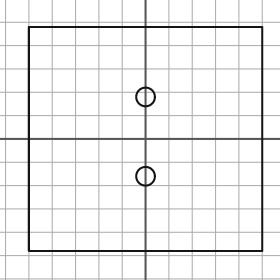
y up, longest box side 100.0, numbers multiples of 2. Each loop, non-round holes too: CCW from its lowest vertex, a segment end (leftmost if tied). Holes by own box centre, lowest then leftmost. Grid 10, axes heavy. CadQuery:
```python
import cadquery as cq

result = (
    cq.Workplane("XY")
    .moveTo(-50.0, -48.0)
    .lineTo(50.0, -48.0)
    .lineTo(50.0, 48.0)
    .lineTo(-50.0, 48.0)
    .close()
    .moveTo(0.0, -16.0)
    .circle(4.0)
    .moveTo(0.0, 18.0)
    .circle(4.0)
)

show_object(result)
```